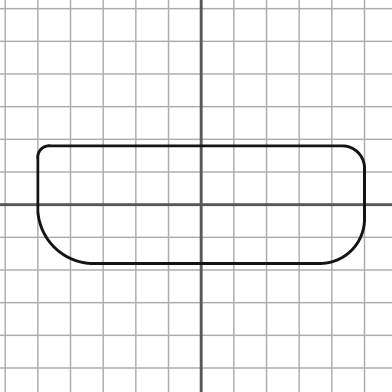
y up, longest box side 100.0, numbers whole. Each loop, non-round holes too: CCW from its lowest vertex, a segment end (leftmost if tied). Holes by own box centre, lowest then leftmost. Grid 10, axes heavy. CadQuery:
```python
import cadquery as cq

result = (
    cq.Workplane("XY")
    .moveTo(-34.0, -18.0)
    .lineTo(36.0, -18.0)
    .threePointArc((46.0, -14.0), (50.0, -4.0))
    .lineTo(50.0, 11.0)
    .threePointArc((48.0, 16.0), (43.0, 18.0))
    .lineTo(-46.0, 18.0)
    .threePointArc((-49.0, 17.0), (-50.0, 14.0))
    .lineTo(-50.0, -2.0)
    .threePointArc((-45.0, -13.0), (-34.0, -18.0))
    .close()
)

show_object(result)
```